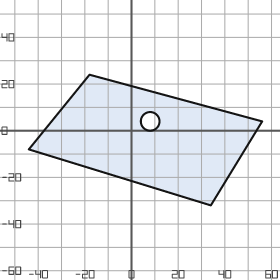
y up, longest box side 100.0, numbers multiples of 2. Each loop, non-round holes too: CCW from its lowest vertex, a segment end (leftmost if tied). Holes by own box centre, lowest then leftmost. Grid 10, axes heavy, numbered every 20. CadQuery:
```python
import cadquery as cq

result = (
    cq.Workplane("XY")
    .moveTo(34.0, -32.0)
    .lineTo(56.0, 4.0)
    .lineTo(-18.0, 24.0)
    .lineTo(-44.0, -8.0)
    .close()
    .moveTo(8.0, 4.0)
    .circle(4.0)
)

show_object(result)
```